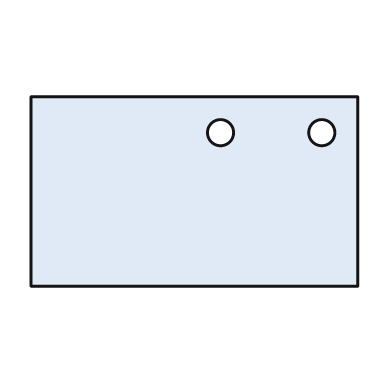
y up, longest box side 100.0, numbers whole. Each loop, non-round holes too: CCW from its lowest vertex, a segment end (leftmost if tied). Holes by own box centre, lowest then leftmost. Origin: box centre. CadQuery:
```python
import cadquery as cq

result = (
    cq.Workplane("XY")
    .moveTo(-50.0, -29.0)
    .lineTo(50.0, -29.0)
    .lineTo(50.0, 29.0)
    .lineTo(-50.0, 29.0)
    .close()
    .moveTo(8.0, 18.0)
    .circle(4.0)
    .moveTo(39.0, 18.0)
    .circle(4.0)
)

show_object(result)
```